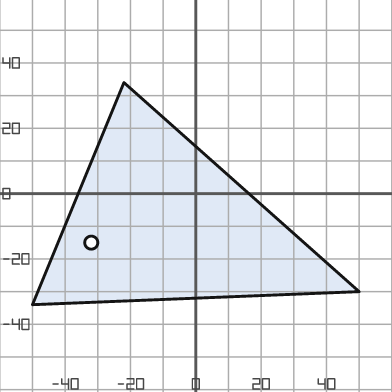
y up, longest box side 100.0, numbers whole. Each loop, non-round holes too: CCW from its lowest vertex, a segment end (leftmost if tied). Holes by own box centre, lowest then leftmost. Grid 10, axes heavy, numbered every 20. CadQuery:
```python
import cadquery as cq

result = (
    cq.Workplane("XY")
    .moveTo(-50.0, -34.0)
    .lineTo(50.0, -30.0)
    .lineTo(-22.0, 34.0)
    .close()
    .moveTo(-32.0, -15.0)
    .circle(2.0)
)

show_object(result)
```